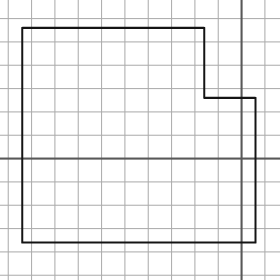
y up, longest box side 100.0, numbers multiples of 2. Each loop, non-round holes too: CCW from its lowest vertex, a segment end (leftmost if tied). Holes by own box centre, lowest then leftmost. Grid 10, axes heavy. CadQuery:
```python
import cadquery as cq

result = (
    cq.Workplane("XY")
    .moveTo(-94.0, -36.0)
    .lineTo(6.0, -36.0)
    .lineTo(6.0, 26.0)
    .lineTo(-16.0, 26.0)
    .lineTo(-16.0, 56.0)
    .lineTo(-94.0, 56.0)
    .close()
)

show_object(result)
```